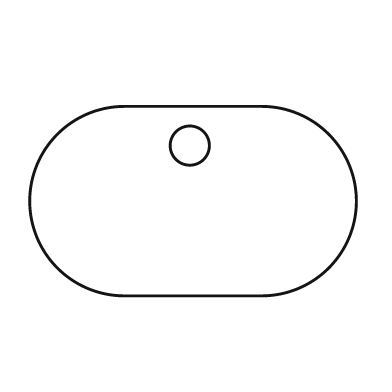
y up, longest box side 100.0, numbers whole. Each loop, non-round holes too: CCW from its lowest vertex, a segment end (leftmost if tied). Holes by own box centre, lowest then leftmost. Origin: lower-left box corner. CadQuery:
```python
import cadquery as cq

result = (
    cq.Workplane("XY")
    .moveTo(29.0, 0.0)
    .lineTo(71.0, 0.0)
    .threePointArc((100.0, 29.0), (71.0, 58.0))
    .lineTo(29.0, 58.0)
    .threePointArc((0.0, 29.0), (29.0, 0.0))
    .close()
    .moveTo(49.0, 46.0)
    .circle(6.0)
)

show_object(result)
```